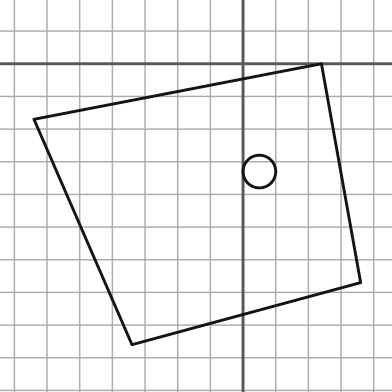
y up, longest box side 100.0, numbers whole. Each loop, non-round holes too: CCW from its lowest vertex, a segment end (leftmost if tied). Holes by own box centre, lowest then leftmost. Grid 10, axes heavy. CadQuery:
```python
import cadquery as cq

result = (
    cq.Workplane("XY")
    .moveTo(-34.0, -86.0)
    .lineTo(36.0, -67.0)
    .lineTo(24.0, 0.0)
    .lineTo(-64.0, -17.0)
    .close()
    .moveTo(5.0, -33.0)
    .circle(5.0)
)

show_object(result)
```